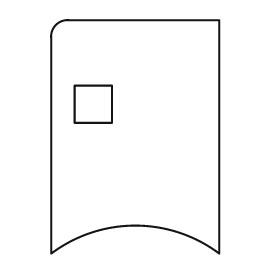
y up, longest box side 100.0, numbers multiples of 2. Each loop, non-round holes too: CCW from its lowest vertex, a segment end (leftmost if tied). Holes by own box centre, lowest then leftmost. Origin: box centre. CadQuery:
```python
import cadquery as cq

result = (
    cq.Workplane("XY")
    .moveTo(-36.0, -50.0)
    .threePointArc((0.0, -38.0), (36.0, -50.0))
    .lineTo(36.0, 50.0)
    .lineTo(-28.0, 50.0)
    .threePointArc((-34.0, 48.0), (-36.0, 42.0))
    .close()
    .moveTo(-26.0, 6.0)
    .lineTo(-10.0, 6.0)
    .lineTo(-10.0, 22.0)
    .lineTo(-26.0, 22.0)
    .close()
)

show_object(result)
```